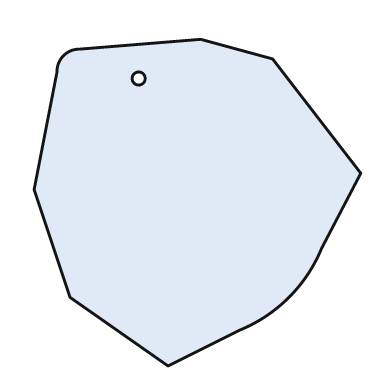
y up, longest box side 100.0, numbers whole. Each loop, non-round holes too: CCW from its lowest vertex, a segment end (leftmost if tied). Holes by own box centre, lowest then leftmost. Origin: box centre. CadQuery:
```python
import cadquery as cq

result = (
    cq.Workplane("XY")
    .moveTo(-9.0, -50.0)
    .lineTo(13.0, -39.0)
    .threePointArc((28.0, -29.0), (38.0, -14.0))
    .lineTo(50.0, 9.0)
    .lineTo(23.0, 44.0)
    .lineTo(1.0, 50.0)
    .lineTo(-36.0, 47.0)
    .threePointArc((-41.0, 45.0), (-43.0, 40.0))
    .lineTo(-50.0, 4.0)
    .lineTo(-39.0, -29.0)
    .close()
    .moveTo(-18.0, 38.0)
    .circle(2.0)
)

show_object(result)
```